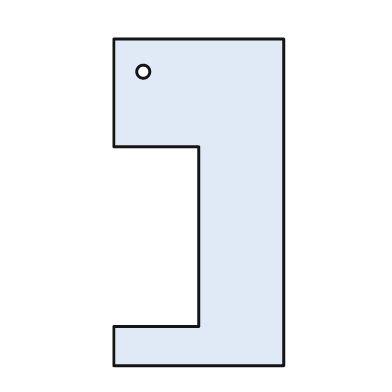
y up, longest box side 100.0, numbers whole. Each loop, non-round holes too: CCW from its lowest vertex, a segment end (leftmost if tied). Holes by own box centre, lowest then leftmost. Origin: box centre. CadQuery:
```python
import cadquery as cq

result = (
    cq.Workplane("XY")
    .moveTo(-26.0, -50.0)
    .lineTo(26.0, -50.0)
    .lineTo(26.0, 50.0)
    .lineTo(-26.0, 50.0)
    .lineTo(-26.0, 17.0)
    .lineTo(0.0, 17.0)
    .lineTo(0.0, -38.0)
    .lineTo(-26.0, -38.0)
    .close()
    .moveTo(-17.0, 40.0)
    .circle(2.0)
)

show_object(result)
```